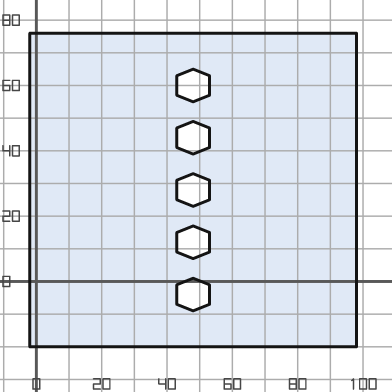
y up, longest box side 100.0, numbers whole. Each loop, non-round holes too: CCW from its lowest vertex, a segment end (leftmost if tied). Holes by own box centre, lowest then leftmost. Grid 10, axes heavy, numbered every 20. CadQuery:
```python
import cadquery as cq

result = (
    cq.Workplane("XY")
    .moveTo(-2.0, -20.0)
    .lineTo(98.0, -20.0)
    .lineTo(98.0, 76.0)
    .lineTo(-2.0, 76.0)
    .close()
    .moveTo(48.0, -9.0)
    .lineTo(53.0, -7.0)
    .lineTo(53.0, -1.0)
    .lineTo(48.0, 1.0)
    .lineTo(43.0, -1.0)
    .lineTo(43.0, -7.0)
    .close()
    .moveTo(48.0, 7.0)
    .lineTo(53.0, 9.0)
    .lineTo(53.0, 15.0)
    .lineTo(48.0, 17.0)
    .lineTo(43.0, 15.0)
    .lineTo(43.0, 9.0)
    .close()
    .moveTo(48.0, 23.0)
    .lineTo(53.0, 25.0)
    .lineTo(53.0, 31.0)
    .lineTo(48.0, 33.0)
    .lineTo(43.0, 31.0)
    .lineTo(43.0, 25.0)
    .close()
    .moveTo(48.0, 39.0)
    .lineTo(53.0, 41.0)
    .lineTo(53.0, 47.0)
    .lineTo(48.0, 49.0)
    .lineTo(43.0, 47.0)
    .lineTo(43.0, 41.0)
    .close()
    .moveTo(48.0, 55.0)
    .lineTo(53.0, 57.0)
    .lineTo(53.0, 63.0)
    .lineTo(48.0, 65.0)
    .lineTo(43.0, 63.0)
    .lineTo(43.0, 57.0)
    .close()
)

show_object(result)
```